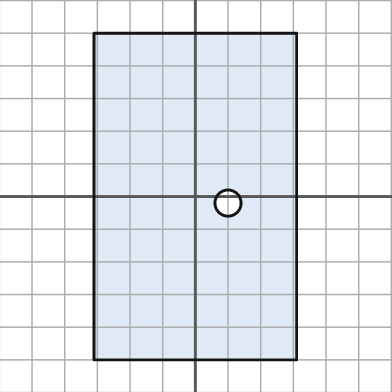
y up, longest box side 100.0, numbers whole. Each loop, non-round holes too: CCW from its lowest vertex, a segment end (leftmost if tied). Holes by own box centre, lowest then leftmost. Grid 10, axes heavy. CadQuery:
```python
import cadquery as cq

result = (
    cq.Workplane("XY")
    .moveTo(-31.0, -50.0)
    .lineTo(31.0, -50.0)
    .lineTo(31.0, 50.0)
    .lineTo(-31.0, 50.0)
    .close()
    .moveTo(10.0, -2.0)
    .circle(4.0)
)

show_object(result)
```